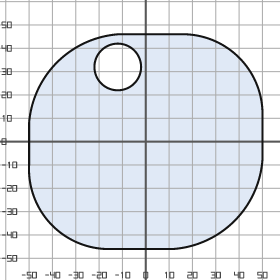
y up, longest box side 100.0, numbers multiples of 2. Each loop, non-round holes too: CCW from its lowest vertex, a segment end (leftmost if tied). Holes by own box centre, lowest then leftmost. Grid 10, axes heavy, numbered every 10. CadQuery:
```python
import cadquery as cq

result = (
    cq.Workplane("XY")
    .moveTo(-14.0, -46.0)
    .lineTo(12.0, -46.0)
    .threePointArc((38.0, -34.0), (50.0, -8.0))
    .lineTo(50.0, 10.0)
    .threePointArc((40.0, 36.0), (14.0, 46.0))
    .lineTo(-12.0, 46.0)
    .threePointArc((-38.0, 34.0), (-50.0, 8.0))
    .lineTo(-50.0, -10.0)
    .threePointArc((-40.0, -36.0), (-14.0, -46.0))
    .close()
    .moveTo(-12.0, 32.0)
    .circle(10.0)
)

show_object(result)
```